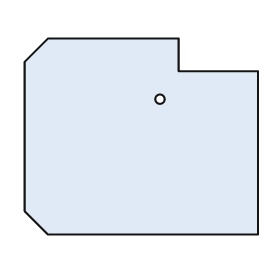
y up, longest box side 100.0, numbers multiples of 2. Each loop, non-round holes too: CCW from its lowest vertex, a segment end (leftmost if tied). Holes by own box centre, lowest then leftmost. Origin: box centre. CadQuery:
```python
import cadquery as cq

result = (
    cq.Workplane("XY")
    .moveTo(-40.0, -42.0)
    .lineTo(50.0, -42.0)
    .lineTo(50.0, 28.0)
    .lineTo(16.0, 28.0)
    .lineTo(16.0, 42.0)
    .lineTo(-40.0, 42.0)
    .lineTo(-50.0, 32.0)
    .lineTo(-50.0, -32.0)
    .close()
    .moveTo(8.0, 16.0)
    .circle(2.0)
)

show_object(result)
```